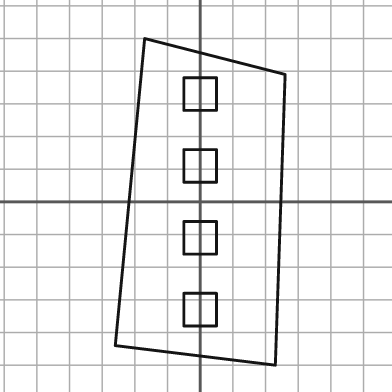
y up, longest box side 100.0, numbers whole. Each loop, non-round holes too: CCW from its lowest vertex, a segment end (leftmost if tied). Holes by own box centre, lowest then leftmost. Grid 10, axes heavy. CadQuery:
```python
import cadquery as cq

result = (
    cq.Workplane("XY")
    .moveTo(23.0, -50.0)
    .lineTo(26.0, 39.0)
    .lineTo(-17.0, 50.0)
    .lineTo(-26.0, -44.0)
    .close()
    .moveTo(-5.0, -38.0)
    .lineTo(5.0, -38.0)
    .lineTo(5.0, -28.0)
    .lineTo(-5.0, -28.0)
    .close()
    .moveTo(-5.0, -16.0)
    .lineTo(5.0, -16.0)
    .lineTo(5.0, -6.0)
    .lineTo(-5.0, -6.0)
    .close()
    .moveTo(-5.0, 6.0)
    .lineTo(5.0, 6.0)
    .lineTo(5.0, 16.0)
    .lineTo(-5.0, 16.0)
    .close()
    .moveTo(-5.0, 28.0)
    .lineTo(5.0, 28.0)
    .lineTo(5.0, 38.0)
    .lineTo(-5.0, 38.0)
    .close()
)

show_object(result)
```